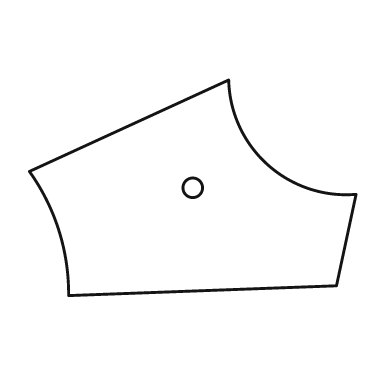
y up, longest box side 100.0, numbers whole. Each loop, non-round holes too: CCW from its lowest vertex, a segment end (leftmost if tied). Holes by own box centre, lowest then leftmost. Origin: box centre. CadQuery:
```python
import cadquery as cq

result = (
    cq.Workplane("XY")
    .moveTo(-38.0, -33.0)
    .lineTo(44.0, -30.0)
    .lineTo(50.0, -2.0)
    .threePointArc((23.0, 7.0), (11.0, 33.0))
    .lineTo(-50.0, 5.0)
    .threePointArc((-41.0, -13.0), (-38.0, -33.0))
    .close()
    .moveTo(0.0, 0.0)
    .circle(3.0)
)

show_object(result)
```